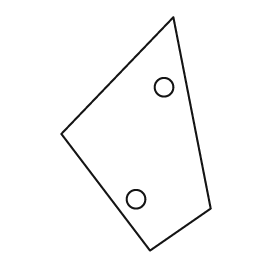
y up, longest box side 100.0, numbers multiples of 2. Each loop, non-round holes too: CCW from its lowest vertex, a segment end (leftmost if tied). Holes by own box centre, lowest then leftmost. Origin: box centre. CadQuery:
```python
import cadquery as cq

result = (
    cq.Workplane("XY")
    .moveTo(6.0, -50.0)
    .lineTo(32.0, -32.0)
    .lineTo(16.0, 50.0)
    .lineTo(-32.0, 0.0)
    .close()
    .moveTo(0.0, -28.0)
    .circle(4.0)
    .moveTo(12.0, 20.0)
    .circle(4.0)
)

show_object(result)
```